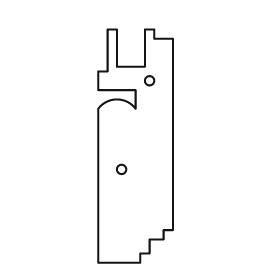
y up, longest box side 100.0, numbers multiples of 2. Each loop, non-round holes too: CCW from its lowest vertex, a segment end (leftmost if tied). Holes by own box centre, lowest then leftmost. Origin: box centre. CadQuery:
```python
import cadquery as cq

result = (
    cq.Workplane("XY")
    .moveTo(-16.0, -50.0)
    .lineTo(2.0, -50.0)
    .lineTo(2.0, -46.0)
    .lineTo(6.0, -46.0)
    .lineTo(6.0, -40.0)
    .lineTo(12.0, -40.0)
    .lineTo(12.0, -36.0)
    .lineTo(16.0, -36.0)
    .lineTo(16.0, 46.0)
    .lineTo(8.0, 46.0)
    .lineTo(8.0, 50.0)
    .lineTo(4.0, 50.0)
    .lineTo(4.0, 34.0)
    .lineTo(-8.0, 34.0)
    .lineTo(-8.0, 50.0)
    .lineTo(-12.0, 50.0)
    .lineTo(-12.0, 32.0)
    .lineTo(-16.0, 32.0)
    .lineTo(-16.0, 24.0)
    .lineTo(0.0, 24.0)
    .lineTo(0.0, 16.0)
    .threePointArc((-8.0, 20.0), (-16.0, 16.0))
    .close()
    .moveTo(-6.0, -10.0)
    .circle(2.0)
    .moveTo(6.0, 28.0)
    .circle(2.0)
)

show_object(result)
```